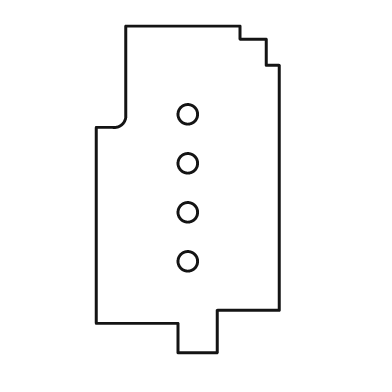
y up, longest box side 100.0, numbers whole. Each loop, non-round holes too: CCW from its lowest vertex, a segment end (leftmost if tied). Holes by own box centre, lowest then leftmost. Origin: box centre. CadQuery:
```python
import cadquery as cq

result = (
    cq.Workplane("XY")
    .moveTo(-3.0, -50.0)
    .lineTo(9.0, -50.0)
    .lineTo(9.0, -37.0)
    .lineTo(28.0, -37.0)
    .lineTo(28.0, 38.0)
    .lineTo(24.0, 38.0)
    .lineTo(24.0, 46.0)
    .lineTo(16.0, 46.0)
    .lineTo(16.0, 50.0)
    .lineTo(-19.0, 50.0)
    .lineTo(-19.0, 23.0)
    .threePointArc((-20.0, 20.0), (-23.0, 19.0))
    .lineTo(-28.0, 19.0)
    .lineTo(-28.0, -41.0)
    .lineTo(-3.0, -41.0)
    .close()
    .moveTo(0.0, -22.0)
    .circle(3.0)
    .moveTo(0.0, -7.0)
    .circle(3.0)
    .moveTo(0.0, 8.0)
    .circle(3.0)
    .moveTo(0.0, 23.0)
    .circle(3.0)
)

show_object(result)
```